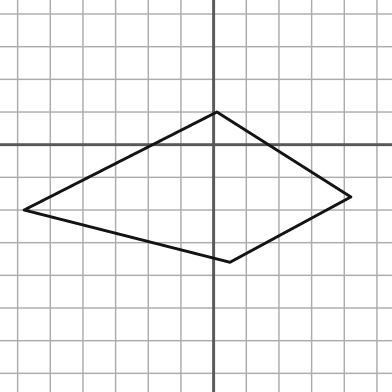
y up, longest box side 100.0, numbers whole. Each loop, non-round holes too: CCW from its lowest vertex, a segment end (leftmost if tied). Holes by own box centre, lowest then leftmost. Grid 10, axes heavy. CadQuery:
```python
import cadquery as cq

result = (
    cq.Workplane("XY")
    .moveTo(5.0, -36.0)
    .lineTo(42.0, -16.0)
    .lineTo(1.0, 10.0)
    .lineTo(-58.0, -20.0)
    .close()
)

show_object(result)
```